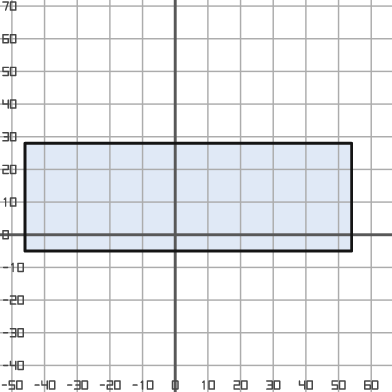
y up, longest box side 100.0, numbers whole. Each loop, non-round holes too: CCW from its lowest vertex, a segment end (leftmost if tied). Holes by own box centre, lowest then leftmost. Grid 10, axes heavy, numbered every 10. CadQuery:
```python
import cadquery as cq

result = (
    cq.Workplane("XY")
    .moveTo(-46.0, -5.0)
    .lineTo(54.0, -5.0)
    .lineTo(54.0, 28.0)
    .lineTo(-46.0, 28.0)
    .close()
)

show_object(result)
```